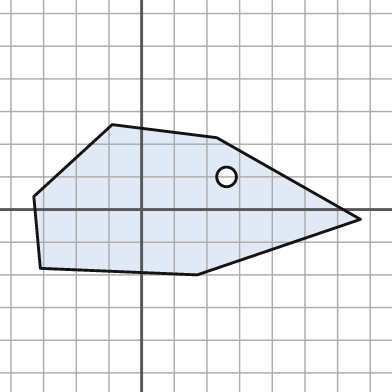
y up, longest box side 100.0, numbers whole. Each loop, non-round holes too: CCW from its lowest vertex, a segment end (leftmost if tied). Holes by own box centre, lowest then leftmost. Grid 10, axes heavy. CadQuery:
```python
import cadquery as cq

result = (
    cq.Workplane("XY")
    .moveTo(17.0, -20.0)
    .lineTo(67.0, -3.0)
    .lineTo(23.0, 22.0)
    .lineTo(-9.0, 26.0)
    .lineTo(-33.0, 4.0)
    .lineTo(-31.0, -18.0)
    .close()
    .moveTo(26.0, 10.0)
    .circle(3.0)
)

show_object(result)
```